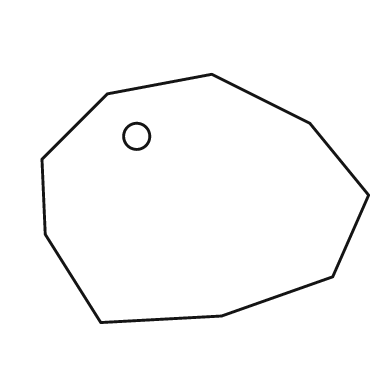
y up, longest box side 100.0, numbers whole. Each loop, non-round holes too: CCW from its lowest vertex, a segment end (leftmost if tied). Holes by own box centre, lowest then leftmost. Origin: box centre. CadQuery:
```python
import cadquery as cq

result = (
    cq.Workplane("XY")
    .moveTo(-32.0, -38.0)
    .lineTo(5.0, -36.0)
    .lineTo(39.0, -24.0)
    .lineTo(50.0, 1.0)
    .lineTo(32.0, 23.0)
    .lineTo(2.0, 38.0)
    .lineTo(-30.0, 32.0)
    .lineTo(-50.0, 12.0)
    .lineTo(-49.0, -11.0)
    .close()
    .moveTo(-21.0, 19.0)
    .circle(4.0)
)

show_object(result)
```